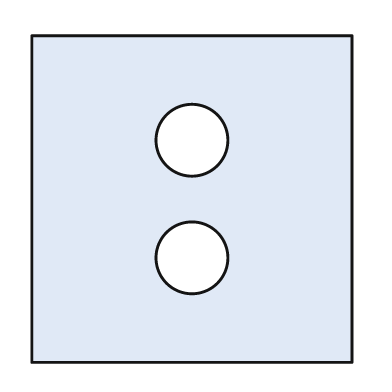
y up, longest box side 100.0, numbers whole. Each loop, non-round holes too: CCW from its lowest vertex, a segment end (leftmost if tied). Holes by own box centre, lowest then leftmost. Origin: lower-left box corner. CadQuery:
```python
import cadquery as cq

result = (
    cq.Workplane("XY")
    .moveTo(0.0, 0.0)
    .lineTo(98.0, 0.0)
    .lineTo(98.0, 100.0)
    .lineTo(0.0, 100.0)
    .close()
    .moveTo(49.0, 32.0)
    .circle(11.0)
    .moveTo(49.0, 68.0)
    .circle(11.0)
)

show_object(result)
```